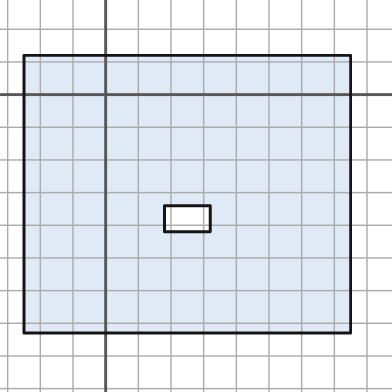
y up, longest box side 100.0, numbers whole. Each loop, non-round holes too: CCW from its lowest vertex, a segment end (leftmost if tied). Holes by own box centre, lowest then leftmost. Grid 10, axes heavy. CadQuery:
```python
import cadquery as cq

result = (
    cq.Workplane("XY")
    .moveTo(-25.0, -73.0)
    .lineTo(75.0, -73.0)
    .lineTo(75.0, 12.0)
    .lineTo(-25.0, 12.0)
    .close()
    .moveTo(18.0, -42.0)
    .lineTo(32.0, -42.0)
    .lineTo(32.0, -34.0)
    .lineTo(18.0, -34.0)
    .close()
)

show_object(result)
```